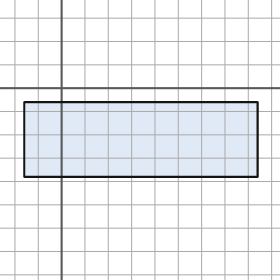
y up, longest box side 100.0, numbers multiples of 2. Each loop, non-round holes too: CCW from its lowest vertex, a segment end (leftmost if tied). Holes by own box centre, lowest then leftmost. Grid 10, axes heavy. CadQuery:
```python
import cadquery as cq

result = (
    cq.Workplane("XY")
    .moveTo(-16.0, -38.0)
    .lineTo(84.0, -38.0)
    .lineTo(84.0, -6.0)
    .lineTo(-16.0, -6.0)
    .close()
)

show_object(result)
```